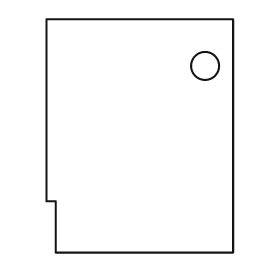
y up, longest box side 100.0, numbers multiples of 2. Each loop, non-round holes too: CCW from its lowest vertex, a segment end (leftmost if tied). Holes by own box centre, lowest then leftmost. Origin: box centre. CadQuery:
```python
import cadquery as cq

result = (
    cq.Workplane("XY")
    .moveTo(-36.0, -50.0)
    .lineTo(40.0, -50.0)
    .lineTo(40.0, 50.0)
    .lineTo(-40.0, 50.0)
    .lineTo(-40.0, -28.0)
    .lineTo(-36.0, -28.0)
    .close()
    .moveTo(28.0, 30.0)
    .circle(6.0)
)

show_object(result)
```